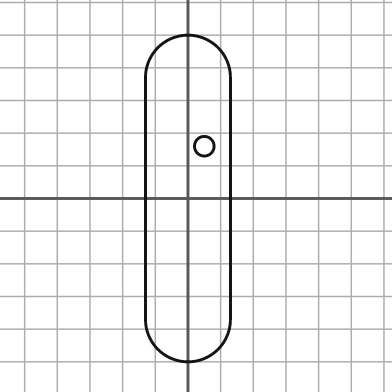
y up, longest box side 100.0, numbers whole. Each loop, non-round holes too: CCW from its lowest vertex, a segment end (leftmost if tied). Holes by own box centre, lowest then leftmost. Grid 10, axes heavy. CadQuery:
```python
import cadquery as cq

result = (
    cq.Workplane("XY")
    .moveTo(-13.0, -37.0)
    .threePointArc((0.0, -50.0), (13.0, -37.0))
    .lineTo(13.0, 37.0)
    .threePointArc((0.0, 50.0), (-13.0, 37.0))
    .close()
    .moveTo(5.0, 16.0)
    .circle(3.0)
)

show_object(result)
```